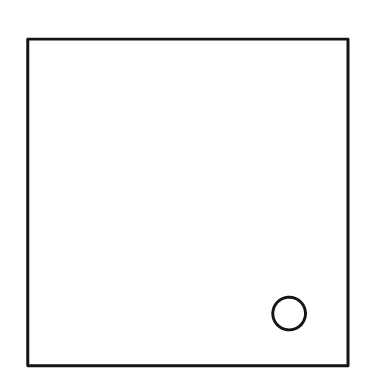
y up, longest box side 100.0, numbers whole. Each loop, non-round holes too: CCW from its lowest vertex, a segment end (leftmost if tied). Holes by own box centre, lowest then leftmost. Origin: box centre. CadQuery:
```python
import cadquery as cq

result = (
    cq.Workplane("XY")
    .moveTo(-49.0, -50.0)
    .lineTo(49.0, -50.0)
    .lineTo(49.0, 50.0)
    .lineTo(-49.0, 50.0)
    .close()
    .moveTo(31.0, -34.0)
    .circle(5.0)
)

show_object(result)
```